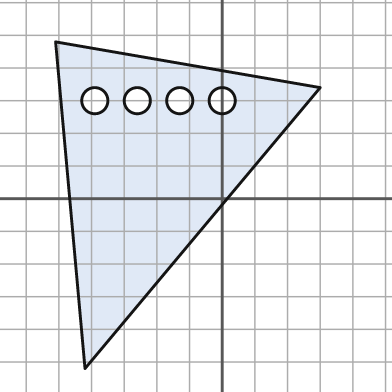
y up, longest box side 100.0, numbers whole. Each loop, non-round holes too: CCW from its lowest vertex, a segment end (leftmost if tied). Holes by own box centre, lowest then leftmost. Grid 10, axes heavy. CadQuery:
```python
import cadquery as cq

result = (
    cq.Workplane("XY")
    .moveTo(-42.0, -52.0)
    .lineTo(30.0, 34.0)
    .lineTo(-51.0, 48.0)
    .close()
    .moveTo(-39.0, 30.0)
    .circle(4.0)
    .moveTo(-26.0, 30.0)
    .circle(4.0)
    .moveTo(-13.0, 30.0)
    .circle(4.0)
    .moveTo(0.0, 30.0)
    .circle(4.0)
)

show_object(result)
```